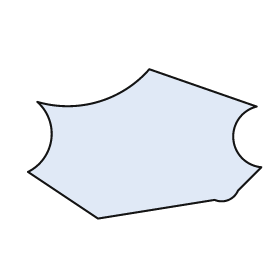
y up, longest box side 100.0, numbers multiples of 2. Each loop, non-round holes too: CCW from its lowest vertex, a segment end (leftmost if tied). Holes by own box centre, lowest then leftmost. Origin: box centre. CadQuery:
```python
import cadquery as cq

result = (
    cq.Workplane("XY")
    .moveTo(-20.0, -32.0)
    .lineTo(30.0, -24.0)
    .threePointArc((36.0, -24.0), (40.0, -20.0))
    .lineTo(50.0, -10.0)
    .threePointArc((38.0, 2.0), (48.0, 16.0))
    .lineTo(2.0, 32.0)
    .threePointArc((-20.0, 18.0), (-46.0, 18.0))
    .threePointArc((-40.0, 2.0), (-50.0, -12.0))
    .close()
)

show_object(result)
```